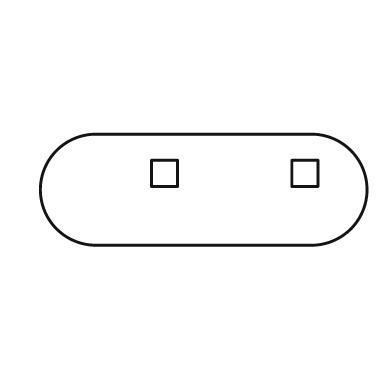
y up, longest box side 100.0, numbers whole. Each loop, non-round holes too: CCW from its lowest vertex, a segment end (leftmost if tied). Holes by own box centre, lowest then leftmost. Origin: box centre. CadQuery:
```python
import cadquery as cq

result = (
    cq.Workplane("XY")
    .moveTo(-33.0, -17.0)
    .lineTo(33.0, -17.0)
    .threePointArc((50.0, 0.0), (33.0, 17.0))
    .lineTo(-33.0, 17.0)
    .threePointArc((-50.0, 0.0), (-33.0, -17.0))
    .close()
    .moveTo(-16.0, 1.0)
    .lineTo(-8.0, 1.0)
    .lineTo(-8.0, 9.0)
    .lineTo(-16.0, 9.0)
    .close()
    .moveTo(27.0, 1.0)
    .lineTo(35.0, 1.0)
    .lineTo(35.0, 9.0)
    .lineTo(27.0, 9.0)
    .close()
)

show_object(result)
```